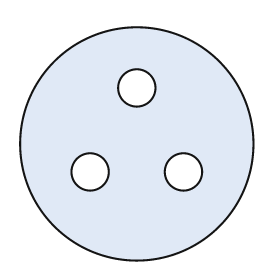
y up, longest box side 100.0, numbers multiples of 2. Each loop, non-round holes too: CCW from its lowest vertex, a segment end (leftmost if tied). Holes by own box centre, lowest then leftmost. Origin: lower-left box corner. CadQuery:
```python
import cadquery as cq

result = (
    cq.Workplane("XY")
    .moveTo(50.0, 50.0)
    .circle(50.0)
    .moveTo(30.0, 38.0)
    .circle(8.0)
    .moveTo(70.0, 38.0)
    .circle(8.0)
    .moveTo(50.0, 74.0)
    .circle(8.0)
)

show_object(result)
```